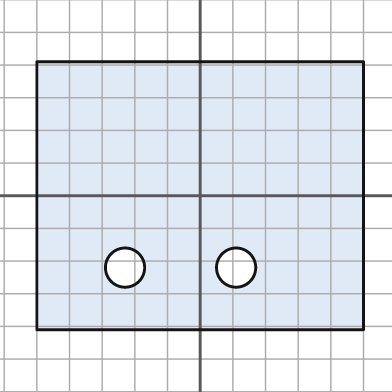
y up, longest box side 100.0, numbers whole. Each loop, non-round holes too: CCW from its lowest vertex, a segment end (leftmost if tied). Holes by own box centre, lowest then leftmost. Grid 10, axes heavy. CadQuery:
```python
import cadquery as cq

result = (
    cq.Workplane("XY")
    .moveTo(-50.0, -41.0)
    .lineTo(50.0, -41.0)
    .lineTo(50.0, 41.0)
    .lineTo(-50.0, 41.0)
    .close()
    .moveTo(-23.0, -22.0)
    .circle(6.0)
    .moveTo(11.0, -22.0)
    .circle(6.0)
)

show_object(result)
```